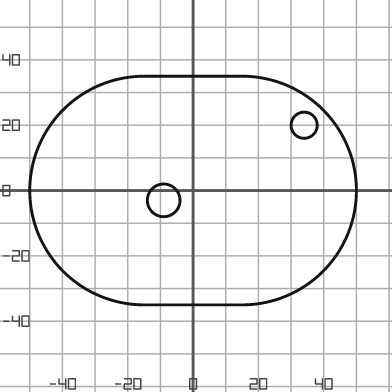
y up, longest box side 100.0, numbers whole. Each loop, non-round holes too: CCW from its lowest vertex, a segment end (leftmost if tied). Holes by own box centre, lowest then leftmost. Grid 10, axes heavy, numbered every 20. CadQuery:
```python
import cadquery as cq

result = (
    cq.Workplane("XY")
    .moveTo(-15.0, -35.0)
    .lineTo(15.0, -35.0)
    .threePointArc((50.0, 0.0), (15.0, 35.0))
    .lineTo(-15.0, 35.0)
    .threePointArc((-50.0, 0.0), (-15.0, -35.0))
    .close()
    .moveTo(-9.0, -3.0)
    .circle(5.0)
    .moveTo(34.0, 20.0)
    .circle(4.0)
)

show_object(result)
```